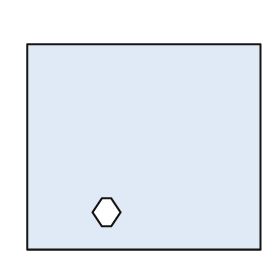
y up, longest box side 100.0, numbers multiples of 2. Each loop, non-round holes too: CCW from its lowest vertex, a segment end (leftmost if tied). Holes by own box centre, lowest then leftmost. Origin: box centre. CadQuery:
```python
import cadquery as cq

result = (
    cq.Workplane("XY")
    .moveTo(-50.0, -44.0)
    .lineTo(50.0, -44.0)
    .lineTo(50.0, 44.0)
    .lineTo(-50.0, 44.0)
    .close()
    .moveTo(-18.0, -34.0)
    .lineTo(-14.0, -34.0)
    .lineTo(-10.0, -28.0)
    .lineTo(-14.0, -22.0)
    .lineTo(-18.0, -22.0)
    .lineTo(-22.0, -28.0)
    .close()
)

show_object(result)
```